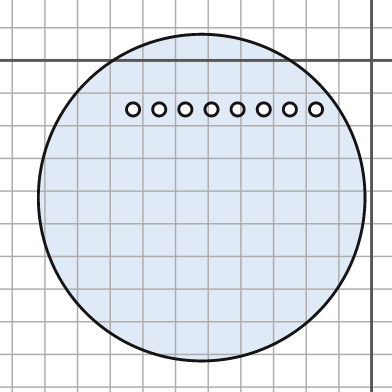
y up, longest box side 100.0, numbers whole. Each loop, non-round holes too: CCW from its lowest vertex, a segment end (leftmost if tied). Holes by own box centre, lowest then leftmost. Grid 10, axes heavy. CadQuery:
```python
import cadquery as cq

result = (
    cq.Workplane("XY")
    .moveTo(-52.0, -42.0)
    .circle(50.0)
    .moveTo(-73.0, -15.0)
    .circle(2.0)
    .moveTo(-65.0, -15.0)
    .circle(2.0)
    .moveTo(-57.0, -15.0)
    .circle(2.0)
    .moveTo(-49.0, -15.0)
    .circle(2.0)
    .moveTo(-41.0, -15.0)
    .circle(2.0)
    .moveTo(-33.0, -15.0)
    .circle(2.0)
    .moveTo(-25.0, -15.0)
    .circle(2.0)
    .moveTo(-17.0, -15.0)
    .circle(2.0)
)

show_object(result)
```